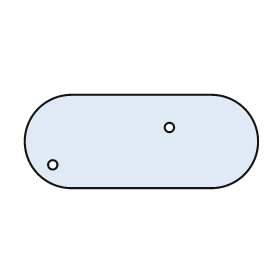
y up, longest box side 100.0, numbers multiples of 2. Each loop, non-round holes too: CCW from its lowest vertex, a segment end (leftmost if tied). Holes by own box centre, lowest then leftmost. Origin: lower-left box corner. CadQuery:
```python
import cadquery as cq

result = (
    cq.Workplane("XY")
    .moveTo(20.0, 0.0)
    .lineTo(80.0, 0.0)
    .threePointArc((100.0, 20.0), (80.0, 40.0))
    .lineTo(20.0, 40.0)
    .threePointArc((0.0, 20.0), (20.0, 0.0))
    .close()
    .moveTo(12.0, 10.0)
    .circle(2.0)
    .moveTo(62.0, 26.0)
    .circle(2.0)
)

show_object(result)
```